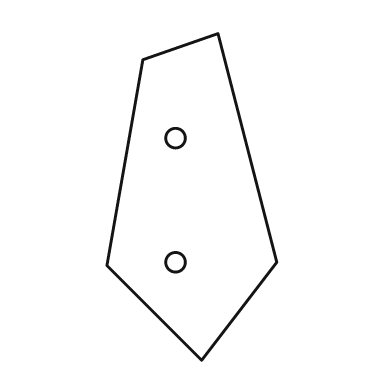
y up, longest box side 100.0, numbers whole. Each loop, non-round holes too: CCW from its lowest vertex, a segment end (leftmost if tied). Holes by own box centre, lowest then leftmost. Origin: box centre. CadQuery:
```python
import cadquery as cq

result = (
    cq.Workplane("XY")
    .moveTo(3.0, -50.0)
    .lineTo(26.0, -20.0)
    .lineTo(8.0, 50.0)
    .lineTo(-15.0, 42.0)
    .lineTo(-26.0, -21.0)
    .close()
    .moveTo(-5.0, -20.0)
    .circle(3.0)
    .moveTo(-5.0, 18.0)
    .circle(3.0)
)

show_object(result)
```